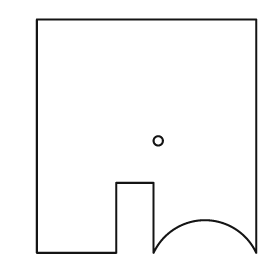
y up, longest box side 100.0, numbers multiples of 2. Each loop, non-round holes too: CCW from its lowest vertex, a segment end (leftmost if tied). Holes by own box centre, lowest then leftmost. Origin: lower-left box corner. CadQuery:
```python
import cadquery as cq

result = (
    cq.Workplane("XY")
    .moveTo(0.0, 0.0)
    .lineTo(34.0, 0.0)
    .lineTo(34.0, 30.0)
    .lineTo(50.0, 30.0)
    .lineTo(50.0, 0.0)
    .threePointArc((72.0, 14.0), (94.0, 0.0))
    .lineTo(94.0, 100.0)
    .lineTo(0.0, 100.0)
    .close()
    .moveTo(52.0, 48.0)
    .circle(2.0)
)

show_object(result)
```